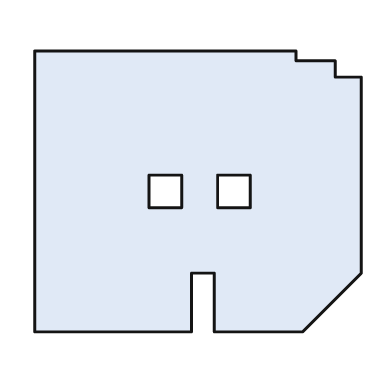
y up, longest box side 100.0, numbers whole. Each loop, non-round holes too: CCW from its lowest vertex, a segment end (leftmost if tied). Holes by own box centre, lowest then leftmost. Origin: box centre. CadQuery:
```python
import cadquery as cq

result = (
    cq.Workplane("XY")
    .moveTo(-50.0, -43.0)
    .lineTo(-2.0, -43.0)
    .lineTo(-2.0, -25.0)
    .lineTo(5.0, -25.0)
    .lineTo(5.0, -43.0)
    .lineTo(32.0, -43.0)
    .lineTo(50.0, -25.0)
    .lineTo(50.0, 35.0)
    .lineTo(42.0, 35.0)
    .lineTo(42.0, 40.0)
    .lineTo(30.0, 40.0)
    .lineTo(30.0, 43.0)
    .lineTo(-50.0, 43.0)
    .close()
    .moveTo(-15.0, -5.0)
    .lineTo(-5.0, -5.0)
    .lineTo(-5.0, 5.0)
    .lineTo(-15.0, 5.0)
    .close()
    .moveTo(6.0, -5.0)
    .lineTo(16.0, -5.0)
    .lineTo(16.0, 5.0)
    .lineTo(6.0, 5.0)
    .close()
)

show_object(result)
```